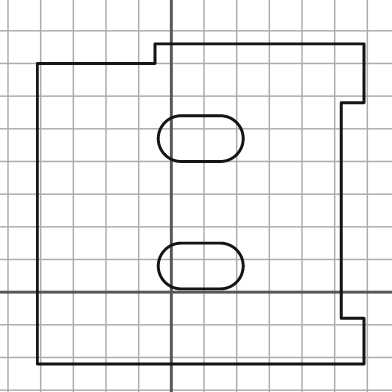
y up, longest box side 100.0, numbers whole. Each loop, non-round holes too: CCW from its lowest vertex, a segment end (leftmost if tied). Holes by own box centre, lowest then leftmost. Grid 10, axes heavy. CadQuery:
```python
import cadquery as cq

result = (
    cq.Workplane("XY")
    .moveTo(-41.0, -22.0)
    .lineTo(59.0, -22.0)
    .lineTo(59.0, -8.0)
    .lineTo(52.0, -8.0)
    .lineTo(52.0, 58.0)
    .lineTo(59.0, 58.0)
    .lineTo(59.0, 76.0)
    .lineTo(-5.0, 76.0)
    .lineTo(-5.0, 70.0)
    .lineTo(-41.0, 70.0)
    .close()
    .moveTo(3.0, 1.0)
    .lineTo(15.0, 1.0)
    .threePointArc((22.0, 8.0), (15.0, 15.0))
    .lineTo(3.0, 15.0)
    .threePointArc((-4.0, 8.0), (3.0, 1.0))
    .close()
    .moveTo(3.0, 40.0)
    .lineTo(15.0, 40.0)
    .threePointArc((22.0, 47.0), (15.0, 54.0))
    .lineTo(3.0, 54.0)
    .threePointArc((-4.0, 47.0), (3.0, 40.0))
    .close()
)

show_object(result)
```